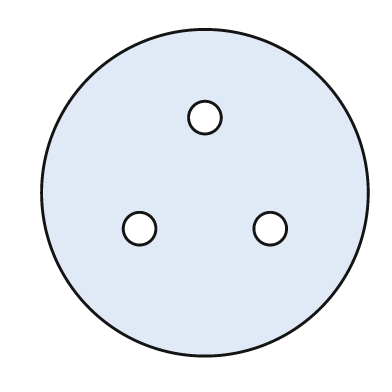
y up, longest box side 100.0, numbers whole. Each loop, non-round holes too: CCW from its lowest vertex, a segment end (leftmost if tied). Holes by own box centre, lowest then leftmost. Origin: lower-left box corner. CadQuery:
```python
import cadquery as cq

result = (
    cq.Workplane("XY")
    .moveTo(50.0, 50.0)
    .circle(50.0)
    .moveTo(30.0, 39.0)
    .circle(5.0)
    .moveTo(70.0, 39.0)
    .circle(5.0)
    .moveTo(50.0, 73.0)
    .circle(5.0)
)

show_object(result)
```